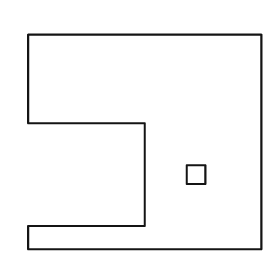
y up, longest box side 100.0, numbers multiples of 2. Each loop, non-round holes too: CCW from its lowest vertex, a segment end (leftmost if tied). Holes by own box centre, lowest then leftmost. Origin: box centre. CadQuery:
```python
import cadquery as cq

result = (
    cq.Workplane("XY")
    .moveTo(-50.0, -46.0)
    .lineTo(50.0, -46.0)
    .lineTo(50.0, 46.0)
    .lineTo(-50.0, 46.0)
    .lineTo(-50.0, 8.0)
    .lineTo(0.0, 8.0)
    .lineTo(0.0, -36.0)
    .lineTo(-50.0, -36.0)
    .close()
    .moveTo(18.0, -18.0)
    .lineTo(26.0, -18.0)
    .lineTo(26.0, -10.0)
    .lineTo(18.0, -10.0)
    .close()
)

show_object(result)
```